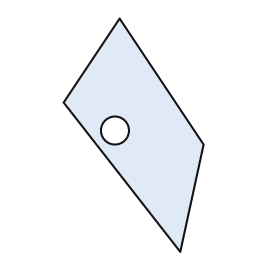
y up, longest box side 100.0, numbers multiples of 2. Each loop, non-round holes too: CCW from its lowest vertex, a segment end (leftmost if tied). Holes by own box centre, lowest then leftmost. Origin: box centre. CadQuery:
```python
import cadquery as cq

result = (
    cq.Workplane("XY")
    .moveTo(20.0, -50.0)
    .lineTo(30.0, -4.0)
    .lineTo(-6.0, 50.0)
    .lineTo(-30.0, 14.0)
    .close()
    .moveTo(-8.0, 2.0)
    .circle(6.0)
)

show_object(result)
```